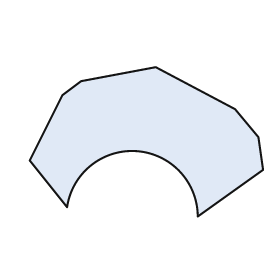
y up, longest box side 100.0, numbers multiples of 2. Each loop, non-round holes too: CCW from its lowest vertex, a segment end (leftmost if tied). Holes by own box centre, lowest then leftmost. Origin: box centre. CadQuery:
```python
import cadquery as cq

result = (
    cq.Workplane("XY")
    .moveTo(22.0, -32.0)
    .lineTo(50.0, -12.0)
    .lineTo(48.0, 2.0)
    .lineTo(38.0, 14.0)
    .lineTo(4.0, 32.0)
    .lineTo(-28.0, 26.0)
    .lineTo(-36.0, 20.0)
    .lineTo(-50.0, -8.0)
    .lineTo(-34.0, -28.0)
    .threePointArc((-4.0, -4.0), (22.0, -32.0))
    .close()
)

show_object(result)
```